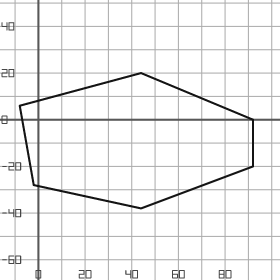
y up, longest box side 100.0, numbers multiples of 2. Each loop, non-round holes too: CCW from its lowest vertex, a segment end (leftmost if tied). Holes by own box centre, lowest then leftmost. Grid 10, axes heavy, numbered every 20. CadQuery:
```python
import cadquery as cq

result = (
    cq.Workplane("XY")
    .moveTo(44.0, -38.0)
    .lineTo(92.0, -20.0)
    .lineTo(92.0, 0.0)
    .lineTo(44.0, 20.0)
    .lineTo(-8.0, 6.0)
    .lineTo(-2.0, -28.0)
    .close()
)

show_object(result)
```